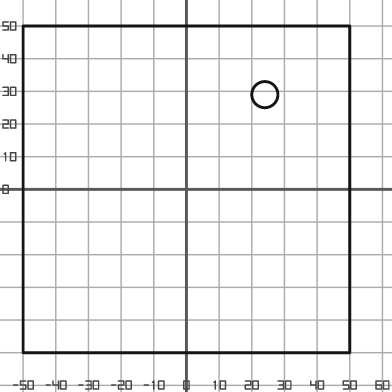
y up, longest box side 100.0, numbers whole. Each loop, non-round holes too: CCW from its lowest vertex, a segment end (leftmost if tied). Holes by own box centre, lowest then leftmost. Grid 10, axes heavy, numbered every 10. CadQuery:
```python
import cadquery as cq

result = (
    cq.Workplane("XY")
    .moveTo(-50.0, -50.0)
    .lineTo(50.0, -50.0)
    .lineTo(50.0, 50.0)
    .lineTo(-50.0, 50.0)
    .close()
    .moveTo(24.0, 29.0)
    .circle(4.0)
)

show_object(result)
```